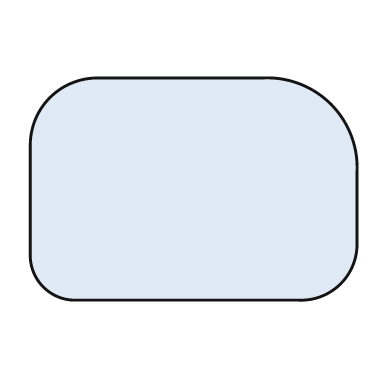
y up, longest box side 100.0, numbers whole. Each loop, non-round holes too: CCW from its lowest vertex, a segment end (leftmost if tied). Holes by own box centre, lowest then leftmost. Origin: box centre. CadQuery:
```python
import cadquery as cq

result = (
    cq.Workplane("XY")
    .moveTo(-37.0, -34.0)
    .lineTo(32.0, -34.0)
    .threePointArc((45.0, -29.0), (50.0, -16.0))
    .lineTo(50.0, 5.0)
    .threePointArc((42.0, 26.0), (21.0, 34.0))
    .lineTo(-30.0, 34.0)
    .threePointArc((-44.0, 28.0), (-50.0, 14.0))
    .lineTo(-50.0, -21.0)
    .threePointArc((-46.0, -30.0), (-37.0, -34.0))
    .close()
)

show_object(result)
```